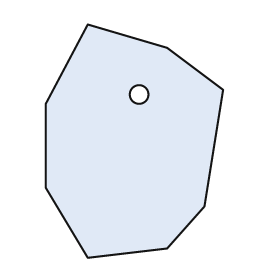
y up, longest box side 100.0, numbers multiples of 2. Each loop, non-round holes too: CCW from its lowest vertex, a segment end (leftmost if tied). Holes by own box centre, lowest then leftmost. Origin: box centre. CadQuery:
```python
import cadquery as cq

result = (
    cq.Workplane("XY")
    .moveTo(-20.0, -50.0)
    .lineTo(14.0, -46.0)
    .lineTo(30.0, -28.0)
    .lineTo(38.0, 22.0)
    .lineTo(14.0, 40.0)
    .lineTo(-20.0, 50.0)
    .lineTo(-38.0, 16.0)
    .lineTo(-38.0, -20.0)
    .close()
    .moveTo(2.0, 20.0)
    .circle(4.0)
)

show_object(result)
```